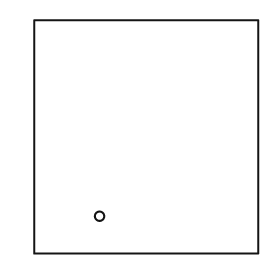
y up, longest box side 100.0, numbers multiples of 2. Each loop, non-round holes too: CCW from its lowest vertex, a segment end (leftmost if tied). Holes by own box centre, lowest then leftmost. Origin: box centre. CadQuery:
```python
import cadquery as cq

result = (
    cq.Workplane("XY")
    .moveTo(-48.0, -50.0)
    .lineTo(48.0, -50.0)
    .lineTo(48.0, 50.0)
    .lineTo(-48.0, 50.0)
    .close()
    .moveTo(-20.0, -34.0)
    .circle(2.0)
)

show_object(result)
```